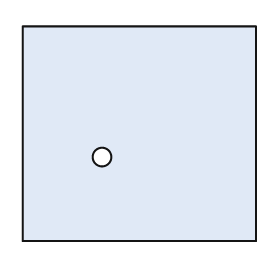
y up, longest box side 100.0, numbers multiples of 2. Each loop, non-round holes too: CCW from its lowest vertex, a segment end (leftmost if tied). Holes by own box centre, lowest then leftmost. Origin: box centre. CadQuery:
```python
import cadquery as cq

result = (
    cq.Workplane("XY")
    .moveTo(-50.0, -46.0)
    .lineTo(50.0, -46.0)
    .lineTo(50.0, 46.0)
    .lineTo(-50.0, 46.0)
    .close()
    .moveTo(-16.0, -10.0)
    .circle(4.0)
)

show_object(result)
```